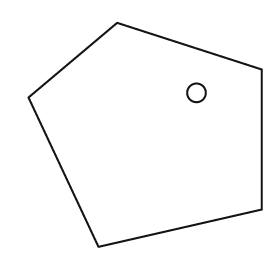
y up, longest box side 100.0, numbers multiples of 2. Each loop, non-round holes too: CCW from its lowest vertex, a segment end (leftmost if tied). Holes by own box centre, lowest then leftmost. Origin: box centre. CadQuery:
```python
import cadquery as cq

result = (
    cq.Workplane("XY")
    .moveTo(-20.0, -48.0)
    .lineTo(50.0, -32.0)
    .lineTo(50.0, 28.0)
    .lineTo(-12.0, 48.0)
    .lineTo(-50.0, 16.0)
    .close()
    .moveTo(22.0, 18.0)
    .circle(4.0)
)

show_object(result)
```